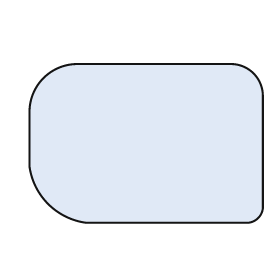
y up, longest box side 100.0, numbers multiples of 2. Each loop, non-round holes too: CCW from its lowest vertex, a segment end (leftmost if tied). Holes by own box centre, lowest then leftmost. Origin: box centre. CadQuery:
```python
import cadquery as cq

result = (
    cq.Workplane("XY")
    .moveTo(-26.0, -34.0)
    .lineTo(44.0, -34.0)
    .threePointArc((48.0, -32.0), (50.0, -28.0))
    .lineTo(50.0, 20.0)
    .threePointArc((46.0, 30.0), (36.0, 34.0))
    .lineTo(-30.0, 34.0)
    .threePointArc((-44.0, 28.0), (-50.0, 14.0))
    .lineTo(-50.0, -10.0)
    .threePointArc((-42.0, -26.0), (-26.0, -34.0))
    .close()
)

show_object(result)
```